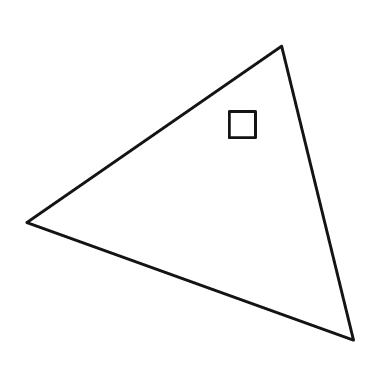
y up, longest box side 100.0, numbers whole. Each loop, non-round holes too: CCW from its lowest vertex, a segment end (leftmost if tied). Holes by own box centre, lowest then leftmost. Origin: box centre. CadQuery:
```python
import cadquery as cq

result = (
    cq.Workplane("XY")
    .moveTo(50.0, -45.0)
    .lineTo(28.0, 45.0)
    .lineTo(-50.0, -9.0)
    .close()
    .moveTo(12.0, 17.0)
    .lineTo(20.0, 17.0)
    .lineTo(20.0, 25.0)
    .lineTo(12.0, 25.0)
    .close()
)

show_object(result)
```